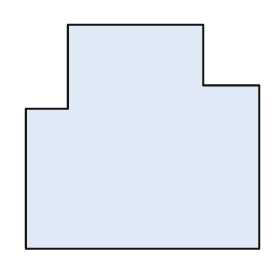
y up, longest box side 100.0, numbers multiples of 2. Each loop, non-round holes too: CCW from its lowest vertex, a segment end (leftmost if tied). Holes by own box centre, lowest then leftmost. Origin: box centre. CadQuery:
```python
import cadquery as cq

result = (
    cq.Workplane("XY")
    .moveTo(-50.0, -48.0)
    .lineTo(50.0, -48.0)
    .lineTo(50.0, 22.0)
    .lineTo(26.0, 22.0)
    .lineTo(26.0, 48.0)
    .lineTo(-32.0, 48.0)
    .lineTo(-32.0, 12.0)
    .lineTo(-50.0, 12.0)
    .close()
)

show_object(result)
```